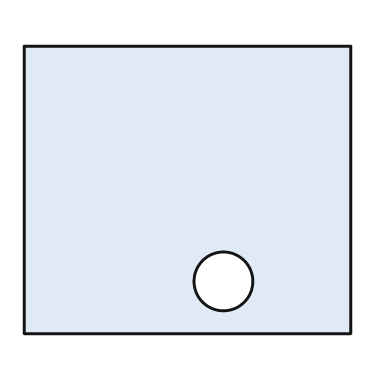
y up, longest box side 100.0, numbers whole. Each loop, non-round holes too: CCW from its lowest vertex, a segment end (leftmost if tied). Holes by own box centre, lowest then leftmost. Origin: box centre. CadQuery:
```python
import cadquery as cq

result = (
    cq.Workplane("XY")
    .moveTo(-50.0, -44.0)
    .lineTo(50.0, -44.0)
    .lineTo(50.0, 44.0)
    .lineTo(-50.0, 44.0)
    .close()
    .moveTo(11.0, -28.0)
    .circle(9.0)
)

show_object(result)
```